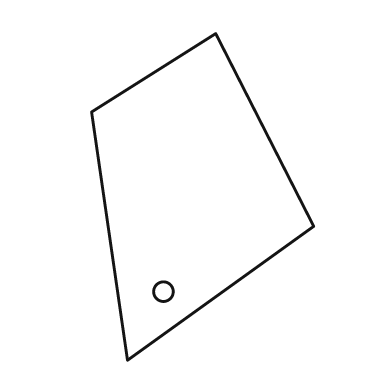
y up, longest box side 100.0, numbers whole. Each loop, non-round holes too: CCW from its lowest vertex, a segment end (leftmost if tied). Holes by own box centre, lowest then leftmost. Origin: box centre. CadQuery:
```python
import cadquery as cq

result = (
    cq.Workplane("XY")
    .moveTo(-23.0, -50.0)
    .lineTo(34.0, -9.0)
    .lineTo(4.0, 50.0)
    .lineTo(-34.0, 26.0)
    .close()
    .moveTo(-12.0, -29.0)
    .circle(3.0)
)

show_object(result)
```